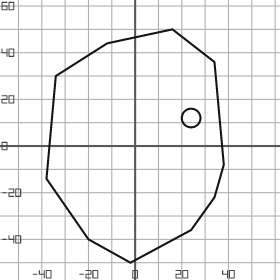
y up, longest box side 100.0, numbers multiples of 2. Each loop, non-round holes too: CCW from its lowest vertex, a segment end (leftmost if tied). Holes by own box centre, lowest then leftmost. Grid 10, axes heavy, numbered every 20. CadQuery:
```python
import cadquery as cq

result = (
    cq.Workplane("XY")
    .moveTo(-2.0, -50.0)
    .lineTo(24.0, -36.0)
    .lineTo(34.0, -22.0)
    .lineTo(38.0, -8.0)
    .lineTo(34.0, 36.0)
    .lineTo(16.0, 50.0)
    .lineTo(-12.0, 44.0)
    .lineTo(-34.0, 30.0)
    .lineTo(-38.0, -14.0)
    .lineTo(-20.0, -40.0)
    .close()
    .moveTo(24.0, 12.0)
    .circle(4.0)
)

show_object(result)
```